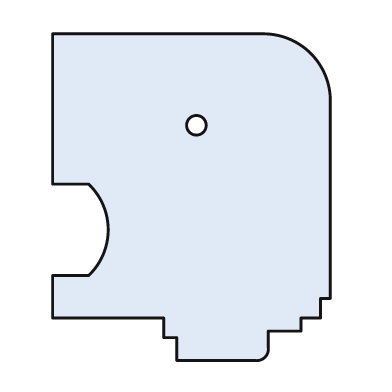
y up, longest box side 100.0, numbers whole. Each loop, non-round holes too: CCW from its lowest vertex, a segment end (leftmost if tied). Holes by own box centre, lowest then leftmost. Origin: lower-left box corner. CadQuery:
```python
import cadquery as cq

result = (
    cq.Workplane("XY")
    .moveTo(38.0, 0.0)
    .lineTo(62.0, 0.0)
    .threePointArc((65.0, 1.0), (66.0, 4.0))
    .lineTo(66.0, 9.0)
    .lineTo(76.0, 9.0)
    .lineTo(76.0, 13.0)
    .lineTo(82.0, 13.0)
    .lineTo(82.0, 19.0)
    .lineTo(85.0, 19.0)
    .lineTo(85.0, 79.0)
    .threePointArc((79.0, 94.0), (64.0, 100.0))
    .lineTo(0.0, 100.0)
    .lineTo(0.0, 54.0)
    .lineTo(11.0, 54.0)
    .threePointArc((17.0, 40.0), (11.0, 26.0))
    .lineTo(0.0, 26.0)
    .lineTo(0.0, 13.0)
    .lineTo(34.0, 13.0)
    .lineTo(34.0, 7.0)
    .lineTo(38.0, 7.0)
    .close()
    .moveTo(44.0, 72.0)
    .circle(3.0)
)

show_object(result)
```